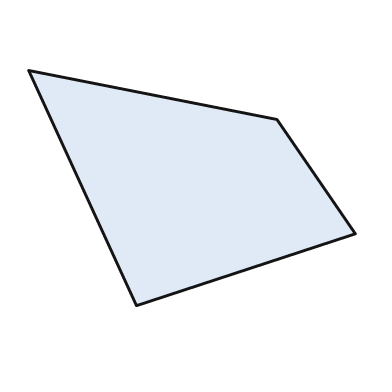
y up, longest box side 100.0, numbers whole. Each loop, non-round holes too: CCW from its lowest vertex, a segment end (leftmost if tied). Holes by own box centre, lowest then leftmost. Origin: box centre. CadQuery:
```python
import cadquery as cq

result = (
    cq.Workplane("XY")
    .moveTo(-17.0, -36.0)
    .lineTo(50.0, -14.0)
    .lineTo(26.0, 21.0)
    .lineTo(-50.0, 36.0)
    .close()
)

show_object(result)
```